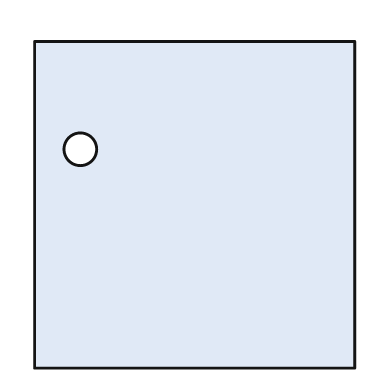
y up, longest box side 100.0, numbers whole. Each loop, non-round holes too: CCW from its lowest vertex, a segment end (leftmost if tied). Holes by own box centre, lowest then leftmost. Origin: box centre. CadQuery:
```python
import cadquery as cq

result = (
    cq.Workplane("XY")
    .moveTo(-49.0, -50.0)
    .lineTo(49.0, -50.0)
    .lineTo(49.0, 50.0)
    .lineTo(-49.0, 50.0)
    .close()
    .moveTo(-35.0, 17.0)
    .circle(5.0)
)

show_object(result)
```